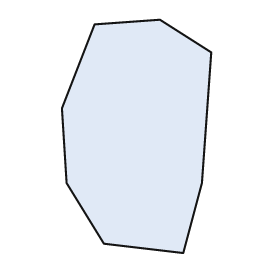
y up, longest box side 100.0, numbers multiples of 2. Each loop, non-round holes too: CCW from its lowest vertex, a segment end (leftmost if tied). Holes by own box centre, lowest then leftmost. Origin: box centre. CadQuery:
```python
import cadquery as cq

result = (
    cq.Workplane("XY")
    .moveTo(20.0, -50.0)
    .lineTo(28.0, -20.0)
    .lineTo(32.0, 36.0)
    .lineTo(10.0, 50.0)
    .lineTo(-18.0, 48.0)
    .lineTo(-32.0, 12.0)
    .lineTo(-30.0, -20.0)
    .lineTo(-14.0, -46.0)
    .close()
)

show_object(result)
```